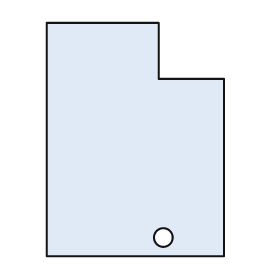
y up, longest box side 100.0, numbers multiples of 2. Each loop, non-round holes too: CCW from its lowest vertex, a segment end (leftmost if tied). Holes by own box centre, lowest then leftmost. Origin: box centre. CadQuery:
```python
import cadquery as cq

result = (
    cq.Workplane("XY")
    .moveTo(-38.0, -50.0)
    .lineTo(38.0, -50.0)
    .lineTo(38.0, 26.0)
    .lineTo(10.0, 26.0)
    .lineTo(10.0, 50.0)
    .lineTo(-38.0, 50.0)
    .close()
    .moveTo(12.0, -42.0)
    .circle(4.0)
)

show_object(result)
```